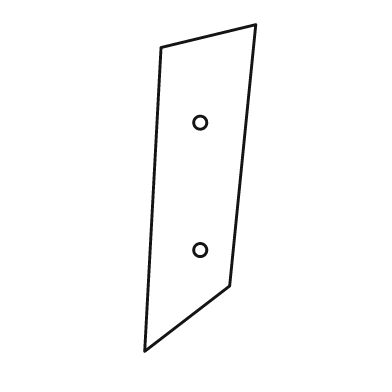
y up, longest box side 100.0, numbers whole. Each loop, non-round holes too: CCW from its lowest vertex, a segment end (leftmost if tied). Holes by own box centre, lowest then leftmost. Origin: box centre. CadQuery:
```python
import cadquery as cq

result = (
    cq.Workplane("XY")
    .moveTo(-17.0, -50.0)
    .lineTo(9.0, -30.0)
    .lineTo(17.0, 50.0)
    .lineTo(-12.0, 43.0)
    .close()
    .moveTo(0.0, -19.0)
    .circle(2.0)
    .moveTo(0.0, 20.0)
    .circle(2.0)
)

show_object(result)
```